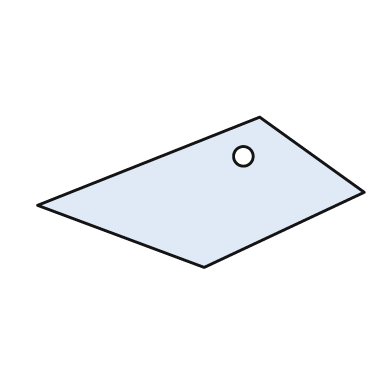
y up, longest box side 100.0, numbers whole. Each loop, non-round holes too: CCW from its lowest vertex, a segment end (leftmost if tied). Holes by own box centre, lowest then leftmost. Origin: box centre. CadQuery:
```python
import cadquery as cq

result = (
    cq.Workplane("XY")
    .moveTo(1.0, -23.0)
    .lineTo(50.0, 0.0)
    .lineTo(18.0, 23.0)
    .lineTo(-50.0, -4.0)
    .close()
    .moveTo(13.0, 11.0)
    .circle(3.0)
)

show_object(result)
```